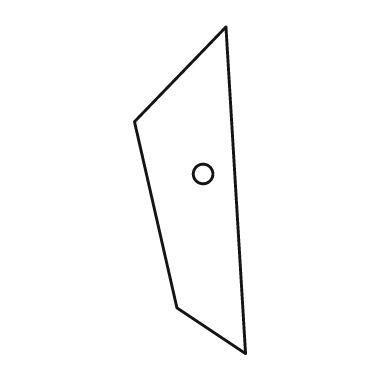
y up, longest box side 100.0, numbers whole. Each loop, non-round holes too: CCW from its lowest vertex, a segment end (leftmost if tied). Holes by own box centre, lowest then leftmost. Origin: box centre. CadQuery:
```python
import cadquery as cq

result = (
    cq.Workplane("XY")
    .moveTo(17.0, -50.0)
    .lineTo(11.0, 50.0)
    .lineTo(-17.0, 21.0)
    .lineTo(-4.0, -36.0)
    .close()
    .moveTo(4.0, 5.0)
    .circle(3.0)
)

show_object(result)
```